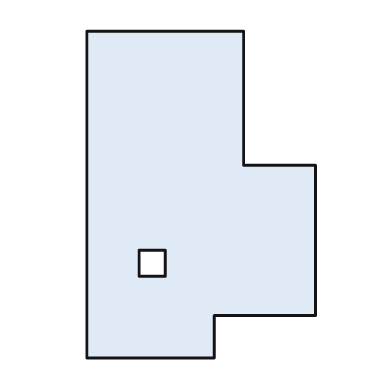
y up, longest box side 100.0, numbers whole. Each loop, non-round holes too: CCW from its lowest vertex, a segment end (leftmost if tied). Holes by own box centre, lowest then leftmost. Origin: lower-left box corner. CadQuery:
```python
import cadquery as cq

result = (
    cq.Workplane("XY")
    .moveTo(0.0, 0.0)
    .lineTo(39.0, 0.0)
    .lineTo(39.0, 13.0)
    .lineTo(70.0, 13.0)
    .lineTo(70.0, 59.0)
    .lineTo(48.0, 59.0)
    .lineTo(48.0, 100.0)
    .lineTo(0.0, 100.0)
    .close()
    .moveTo(16.0, 25.0)
    .lineTo(24.0, 25.0)
    .lineTo(24.0, 33.0)
    .lineTo(16.0, 33.0)
    .close()
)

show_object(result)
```